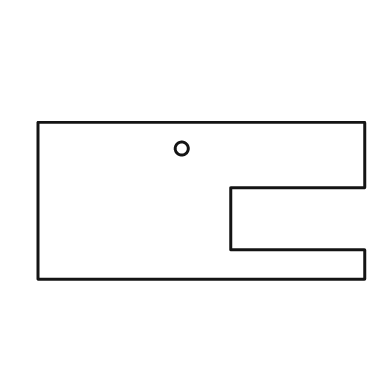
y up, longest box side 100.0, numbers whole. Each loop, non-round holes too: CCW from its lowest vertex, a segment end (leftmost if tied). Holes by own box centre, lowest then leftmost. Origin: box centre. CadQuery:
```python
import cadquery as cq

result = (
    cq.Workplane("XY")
    .moveTo(-50.0, -24.0)
    .lineTo(50.0, -24.0)
    .lineTo(50.0, -15.0)
    .lineTo(9.0, -15.0)
    .lineTo(9.0, 4.0)
    .lineTo(50.0, 4.0)
    .lineTo(50.0, 24.0)
    .lineTo(-50.0, 24.0)
    .close()
    .moveTo(-6.0, 16.0)
    .circle(2.0)
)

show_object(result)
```